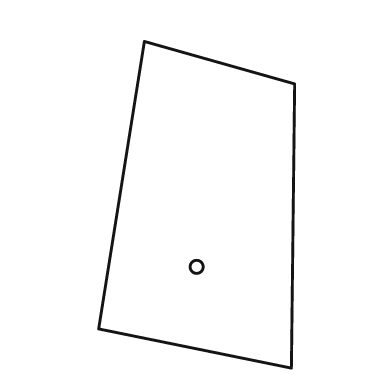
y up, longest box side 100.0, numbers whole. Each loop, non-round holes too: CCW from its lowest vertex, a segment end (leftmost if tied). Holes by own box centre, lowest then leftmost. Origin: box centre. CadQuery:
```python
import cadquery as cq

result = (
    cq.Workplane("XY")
    .moveTo(29.0, -50.0)
    .lineTo(30.0, 37.0)
    .lineTo(-16.0, 50.0)
    .lineTo(-30.0, -38.0)
    .close()
    .moveTo(0.0, -19.0)
    .circle(2.0)
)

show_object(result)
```